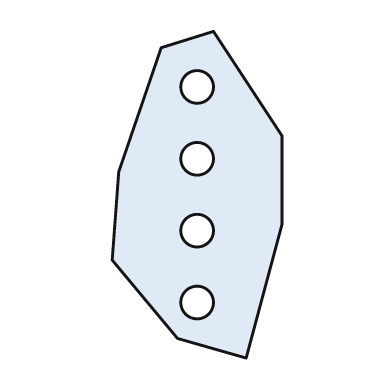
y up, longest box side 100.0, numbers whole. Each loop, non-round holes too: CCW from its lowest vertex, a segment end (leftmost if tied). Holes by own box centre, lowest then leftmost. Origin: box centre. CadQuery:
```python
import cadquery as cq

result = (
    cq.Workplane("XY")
    .moveTo(15.0, -50.0)
    .lineTo(26.0, -9.0)
    .lineTo(26.0, 18.0)
    .lineTo(5.0, 50.0)
    .lineTo(-11.0, 45.0)
    .lineTo(-24.0, 7.0)
    .lineTo(-26.0, -20.0)
    .lineTo(-6.0, -44.0)
    .close()
    .moveTo(0.0, -33.0)
    .circle(5.0)
    .moveTo(0.0, -11.0)
    .circle(5.0)
    .moveTo(0.0, 11.0)
    .circle(5.0)
    .moveTo(0.0, 33.0)
    .circle(5.0)
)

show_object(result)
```